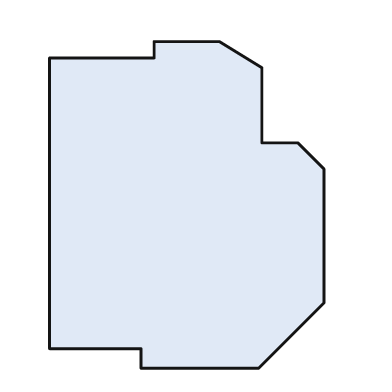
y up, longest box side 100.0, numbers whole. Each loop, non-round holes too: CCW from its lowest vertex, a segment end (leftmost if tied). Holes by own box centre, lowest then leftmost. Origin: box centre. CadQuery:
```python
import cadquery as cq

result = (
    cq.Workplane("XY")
    .moveTo(-14.0, -50.0)
    .lineTo(22.0, -50.0)
    .lineTo(42.0, -30.0)
    .lineTo(42.0, 11.0)
    .lineTo(34.0, 19.0)
    .lineTo(23.0, 19.0)
    .lineTo(23.0, 42.0)
    .lineTo(10.0, 50.0)
    .lineTo(-10.0, 50.0)
    .lineTo(-10.0, 45.0)
    .lineTo(-42.0, 45.0)
    .lineTo(-42.0, -44.0)
    .lineTo(-14.0, -44.0)
    .close()
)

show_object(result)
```